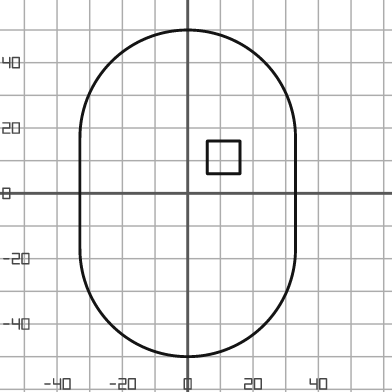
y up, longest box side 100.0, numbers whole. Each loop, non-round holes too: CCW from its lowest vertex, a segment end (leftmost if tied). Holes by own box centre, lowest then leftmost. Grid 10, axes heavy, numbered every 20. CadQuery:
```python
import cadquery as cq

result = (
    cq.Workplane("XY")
    .moveTo(-33.0, -17.0)
    .threePointArc((0.0, -50.0), (33.0, -17.0))
    .lineTo(33.0, 17.0)
    .threePointArc((0.0, 50.0), (-33.0, 17.0))
    .close()
    .moveTo(6.0, 6.0)
    .lineTo(16.0, 6.0)
    .lineTo(16.0, 16.0)
    .lineTo(6.0, 16.0)
    .close()
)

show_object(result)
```